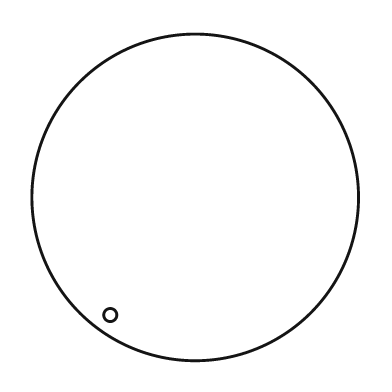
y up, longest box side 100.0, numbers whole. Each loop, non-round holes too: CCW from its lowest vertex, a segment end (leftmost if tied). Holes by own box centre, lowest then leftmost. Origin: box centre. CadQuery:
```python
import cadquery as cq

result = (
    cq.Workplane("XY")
    .moveTo(0.0, 0.0)
    .circle(50.0)
    .moveTo(-26.0, -36.0)
    .circle(2.0)
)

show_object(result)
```